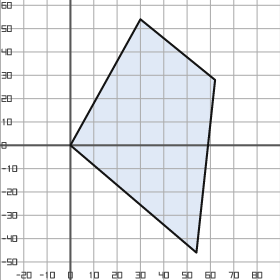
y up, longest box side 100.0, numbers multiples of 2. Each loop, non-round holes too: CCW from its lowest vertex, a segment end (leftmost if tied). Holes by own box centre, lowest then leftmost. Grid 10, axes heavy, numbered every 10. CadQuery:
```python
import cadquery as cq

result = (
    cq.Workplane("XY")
    .moveTo(54.0, -46.0)
    .lineTo(62.0, 28.0)
    .lineTo(30.0, 54.0)
    .lineTo(0.0, 0.0)
    .close()
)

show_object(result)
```